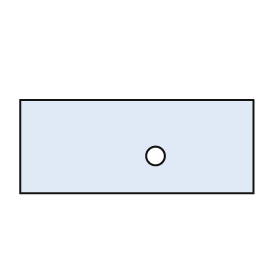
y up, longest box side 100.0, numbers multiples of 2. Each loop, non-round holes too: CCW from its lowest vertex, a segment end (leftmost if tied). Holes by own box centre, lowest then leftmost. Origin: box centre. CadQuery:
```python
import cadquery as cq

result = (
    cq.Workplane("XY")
    .moveTo(-50.0, -20.0)
    .lineTo(50.0, -20.0)
    .lineTo(50.0, 20.0)
    .lineTo(-50.0, 20.0)
    .close()
    .moveTo(8.0, -4.0)
    .circle(4.0)
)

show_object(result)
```